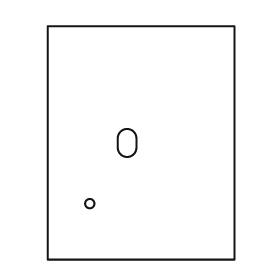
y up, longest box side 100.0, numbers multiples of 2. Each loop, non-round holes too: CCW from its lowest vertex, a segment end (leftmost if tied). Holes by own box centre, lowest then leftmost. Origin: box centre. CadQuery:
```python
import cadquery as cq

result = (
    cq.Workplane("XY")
    .moveTo(-40.0, -50.0)
    .lineTo(40.0, -50.0)
    .lineTo(40.0, 50.0)
    .lineTo(-40.0, 50.0)
    .close()
    .moveTo(-22.0, -26.0)
    .circle(2.0)
    .moveTo(-10.0, -2.0)
    .threePointArc((-6.0, -6.0), (-2.0, -2.0))
    .lineTo(-2.0, 2.0)
    .threePointArc((-6.0, 6.0), (-10.0, 2.0))
    .close()
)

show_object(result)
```